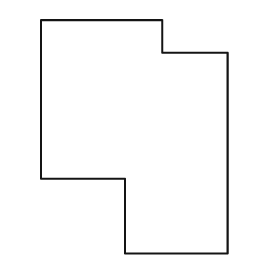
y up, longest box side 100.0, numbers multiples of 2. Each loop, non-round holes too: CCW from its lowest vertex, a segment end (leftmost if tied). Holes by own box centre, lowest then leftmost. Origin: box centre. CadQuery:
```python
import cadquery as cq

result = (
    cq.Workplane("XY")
    .moveTo(-4.0, -50.0)
    .lineTo(40.0, -50.0)
    .lineTo(40.0, 36.0)
    .lineTo(12.0, 36.0)
    .lineTo(12.0, 50.0)
    .lineTo(-40.0, 50.0)
    .lineTo(-40.0, -18.0)
    .lineTo(-4.0, -18.0)
    .close()
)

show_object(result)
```